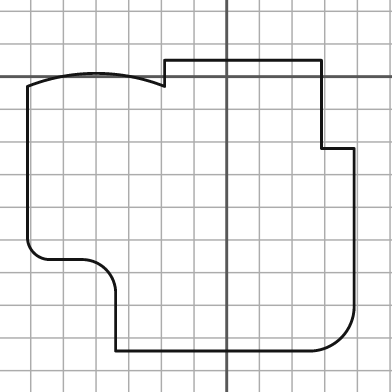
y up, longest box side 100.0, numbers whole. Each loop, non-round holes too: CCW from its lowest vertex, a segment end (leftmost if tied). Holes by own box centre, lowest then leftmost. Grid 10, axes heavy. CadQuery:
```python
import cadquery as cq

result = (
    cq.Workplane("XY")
    .moveTo(-34.0, -84.0)
    .lineTo(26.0, -84.0)
    .threePointArc((35.0, -80.0), (39.0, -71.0))
    .lineTo(39.0, -22.0)
    .lineTo(29.0, -22.0)
    .lineTo(29.0, 5.0)
    .lineTo(-19.0, 5.0)
    .lineTo(-19.0, -3.0)
    .threePointArc((-40.0, 1.0), (-61.0, -3.0))
    .lineTo(-61.0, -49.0)
    .threePointArc((-59.0, -54.0), (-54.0, -56.0))
    .lineTo(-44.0, -56.0)
    .threePointArc((-37.0, -59.0), (-34.0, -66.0))
    .close()
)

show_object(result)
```